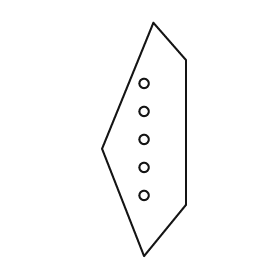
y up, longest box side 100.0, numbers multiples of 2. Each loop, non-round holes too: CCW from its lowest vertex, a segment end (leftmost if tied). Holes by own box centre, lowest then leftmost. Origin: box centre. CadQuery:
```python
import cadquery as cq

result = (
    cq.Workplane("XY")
    .moveTo(0.0, -50.0)
    .lineTo(18.0, -28.0)
    .lineTo(18.0, 34.0)
    .lineTo(4.0, 50.0)
    .lineTo(-18.0, -4.0)
    .close()
    .moveTo(0.0, -24.0)
    .circle(2.0)
    .moveTo(0.0, -12.0)
    .circle(2.0)
    .moveTo(0.0, 0.0)
    .circle(2.0)
    .moveTo(0.0, 12.0)
    .circle(2.0)
    .moveTo(0.0, 24.0)
    .circle(2.0)
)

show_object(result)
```